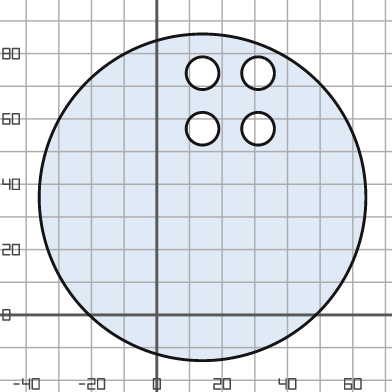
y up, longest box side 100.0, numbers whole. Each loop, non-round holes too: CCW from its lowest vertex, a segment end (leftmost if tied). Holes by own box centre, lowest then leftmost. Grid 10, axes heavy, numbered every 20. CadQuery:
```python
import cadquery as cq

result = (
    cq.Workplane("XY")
    .moveTo(14.0, 36.0)
    .circle(50.0)
    .moveTo(14.0, 57.0)
    .circle(5.0)
    .moveTo(31.0, 57.0)
    .circle(5.0)
    .moveTo(14.0, 74.0)
    .circle(5.0)
    .moveTo(31.0, 74.0)
    .circle(5.0)
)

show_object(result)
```